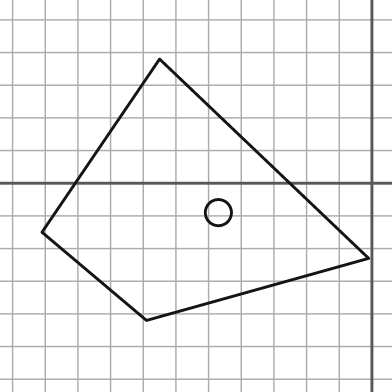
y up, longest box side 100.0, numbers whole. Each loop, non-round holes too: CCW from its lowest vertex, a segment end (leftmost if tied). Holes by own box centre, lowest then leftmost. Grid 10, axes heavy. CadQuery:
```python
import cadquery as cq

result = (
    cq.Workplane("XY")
    .moveTo(-69.0, -42.0)
    .lineTo(-1.0, -23.0)
    .lineTo(-65.0, 38.0)
    .lineTo(-101.0, -15.0)
    .close()
    .moveTo(-47.0, -9.0)
    .circle(4.0)
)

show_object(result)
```